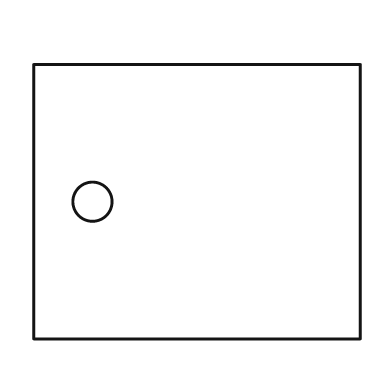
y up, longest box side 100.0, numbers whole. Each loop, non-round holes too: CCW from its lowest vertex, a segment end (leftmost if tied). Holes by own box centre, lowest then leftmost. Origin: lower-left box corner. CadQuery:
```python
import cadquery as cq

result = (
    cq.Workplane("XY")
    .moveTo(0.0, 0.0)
    .lineTo(100.0, 0.0)
    .lineTo(100.0, 84.0)
    .lineTo(0.0, 84.0)
    .close()
    .moveTo(18.0, 42.0)
    .circle(6.0)
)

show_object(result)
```